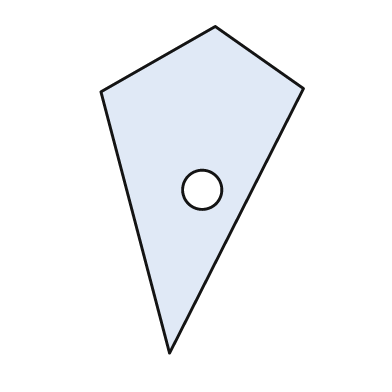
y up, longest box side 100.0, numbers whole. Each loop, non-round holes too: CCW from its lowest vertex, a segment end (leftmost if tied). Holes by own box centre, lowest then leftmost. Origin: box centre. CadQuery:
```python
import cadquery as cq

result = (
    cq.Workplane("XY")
    .moveTo(-10.0, -50.0)
    .lineTo(31.0, 31.0)
    .lineTo(4.0, 50.0)
    .lineTo(-31.0, 30.0)
    .close()
    .moveTo(0.0, 0.0)
    .circle(6.0)
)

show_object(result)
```